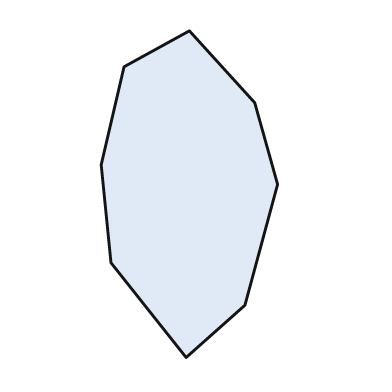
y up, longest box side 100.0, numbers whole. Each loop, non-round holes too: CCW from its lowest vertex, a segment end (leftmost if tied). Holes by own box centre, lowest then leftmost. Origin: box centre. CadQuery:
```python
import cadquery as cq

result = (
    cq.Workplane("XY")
    .moveTo(-1.0, -50.0)
    .lineTo(17.0, -34.0)
    .lineTo(27.0, 3.0)
    .lineTo(20.0, 28.0)
    .lineTo(0.0, 50.0)
    .lineTo(-20.0, 39.0)
    .lineTo(-27.0, 9.0)
    .lineTo(-24.0, -21.0)
    .close()
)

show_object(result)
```